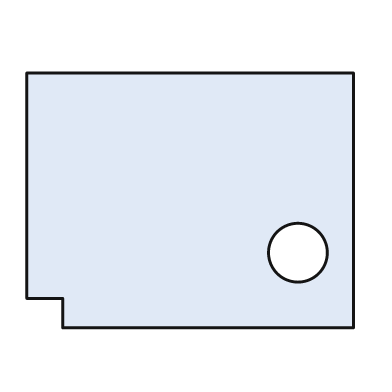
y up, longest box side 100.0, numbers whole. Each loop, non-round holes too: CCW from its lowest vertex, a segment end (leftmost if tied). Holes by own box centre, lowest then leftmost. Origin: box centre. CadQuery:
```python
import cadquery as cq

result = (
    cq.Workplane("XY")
    .moveTo(-39.0, -39.0)
    .lineTo(50.0, -39.0)
    .lineTo(50.0, 39.0)
    .lineTo(-50.0, 39.0)
    .lineTo(-50.0, -30.0)
    .lineTo(-39.0, -30.0)
    .close()
    .moveTo(33.0, -16.0)
    .circle(9.0)
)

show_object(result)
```